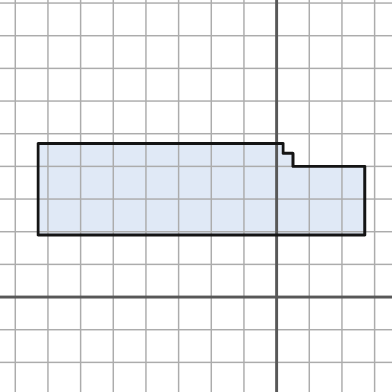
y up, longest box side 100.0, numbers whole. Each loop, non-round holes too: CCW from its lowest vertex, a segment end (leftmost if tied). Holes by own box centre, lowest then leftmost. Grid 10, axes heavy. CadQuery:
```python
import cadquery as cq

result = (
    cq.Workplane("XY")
    .moveTo(-73.0, 19.0)
    .lineTo(27.0, 19.0)
    .lineTo(27.0, 40.0)
    .lineTo(5.0, 40.0)
    .lineTo(5.0, 44.0)
    .lineTo(2.0, 44.0)
    .lineTo(2.0, 47.0)
    .lineTo(-73.0, 47.0)
    .close()
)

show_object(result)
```